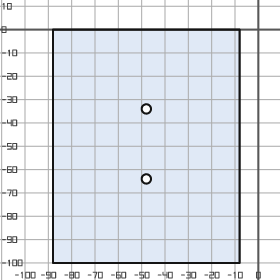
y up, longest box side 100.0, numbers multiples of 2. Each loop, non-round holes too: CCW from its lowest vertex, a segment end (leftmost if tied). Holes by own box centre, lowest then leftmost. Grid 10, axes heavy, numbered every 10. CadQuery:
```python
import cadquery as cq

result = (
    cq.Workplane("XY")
    .moveTo(-88.0, -100.0)
    .lineTo(-8.0, -100.0)
    .lineTo(-8.0, 0.0)
    .lineTo(-88.0, 0.0)
    .close()
    .moveTo(-48.0, -64.0)
    .circle(2.0)
    .moveTo(-48.0, -34.0)
    .circle(2.0)
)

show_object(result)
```